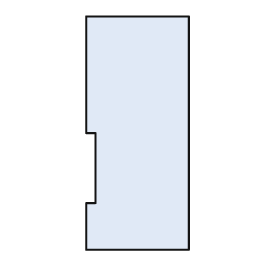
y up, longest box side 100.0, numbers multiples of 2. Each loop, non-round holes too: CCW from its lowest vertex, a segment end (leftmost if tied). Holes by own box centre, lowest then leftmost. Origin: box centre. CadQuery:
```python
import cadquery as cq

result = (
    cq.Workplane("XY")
    .moveTo(-22.0, -50.0)
    .lineTo(22.0, -50.0)
    .lineTo(22.0, 50.0)
    .lineTo(-22.0, 50.0)
    .lineTo(-22.0, 0.0)
    .lineTo(-18.0, 0.0)
    .lineTo(-18.0, -30.0)
    .lineTo(-22.0, -30.0)
    .close()
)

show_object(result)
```